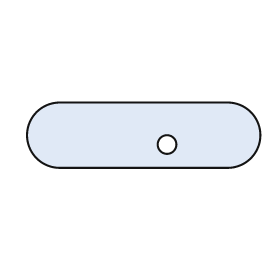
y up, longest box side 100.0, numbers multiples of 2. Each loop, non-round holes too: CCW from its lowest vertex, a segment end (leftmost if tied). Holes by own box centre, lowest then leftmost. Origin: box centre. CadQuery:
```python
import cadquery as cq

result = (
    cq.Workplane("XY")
    .moveTo(-36.0, -14.0)
    .lineTo(36.0, -14.0)
    .threePointArc((50.0, 0.0), (36.0, 14.0))
    .lineTo(-36.0, 14.0)
    .threePointArc((-50.0, 0.0), (-36.0, -14.0))
    .close()
    .moveTo(10.0, -4.0)
    .circle(4.0)
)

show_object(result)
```